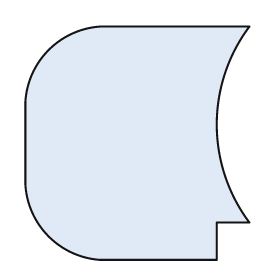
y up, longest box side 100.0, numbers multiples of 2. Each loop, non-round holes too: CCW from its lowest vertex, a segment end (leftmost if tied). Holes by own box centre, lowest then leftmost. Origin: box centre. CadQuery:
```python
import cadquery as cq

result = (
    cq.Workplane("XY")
    .moveTo(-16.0, -50.0)
    .lineTo(34.0, -50.0)
    .lineTo(34.0, -34.0)
    .lineTo(48.0, -34.0)
    .threePointArc((34.0, 8.0), (48.0, 50.0))
    .lineTo(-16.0, 50.0)
    .threePointArc((-38.0, 40.0), (-48.0, 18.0))
    .lineTo(-48.0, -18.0)
    .threePointArc((-38.0, -40.0), (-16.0, -50.0))
    .close()
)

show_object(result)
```